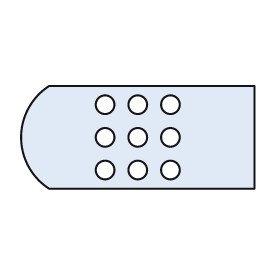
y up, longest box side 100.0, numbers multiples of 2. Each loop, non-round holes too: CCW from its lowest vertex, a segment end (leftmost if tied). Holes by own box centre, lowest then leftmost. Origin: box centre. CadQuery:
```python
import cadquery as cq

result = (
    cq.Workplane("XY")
    .moveTo(-38.0, -22.0)
    .lineTo(50.0, -22.0)
    .lineTo(50.0, 22.0)
    .lineTo(-38.0, 22.0)
    .threePointArc((-50.0, 0.0), (-38.0, -22.0))
    .close()
    .moveTo(-14.0, -14.0)
    .circle(4.0)
    .moveTo(0.0, -14.0)
    .circle(4.0)
    .moveTo(14.0, -14.0)
    .circle(4.0)
    .moveTo(-14.0, 0.0)
    .circle(4.0)
    .moveTo(0.0, 0.0)
    .circle(4.0)
    .moveTo(14.0, 0.0)
    .circle(4.0)
    .moveTo(-14.0, 14.0)
    .circle(4.0)
    .moveTo(0.0, 14.0)
    .circle(4.0)
    .moveTo(14.0, 14.0)
    .circle(4.0)
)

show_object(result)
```